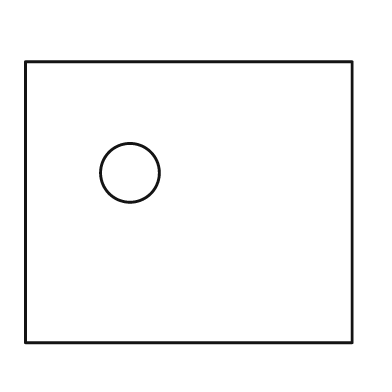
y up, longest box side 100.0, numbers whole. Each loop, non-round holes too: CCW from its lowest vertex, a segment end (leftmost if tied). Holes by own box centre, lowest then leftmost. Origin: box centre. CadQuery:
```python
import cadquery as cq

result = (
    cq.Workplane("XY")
    .moveTo(-50.0, -43.0)
    .lineTo(50.0, -43.0)
    .lineTo(50.0, 43.0)
    .lineTo(-50.0, 43.0)
    .close()
    .moveTo(-18.0, 9.0)
    .circle(9.0)
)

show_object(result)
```